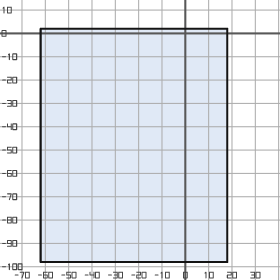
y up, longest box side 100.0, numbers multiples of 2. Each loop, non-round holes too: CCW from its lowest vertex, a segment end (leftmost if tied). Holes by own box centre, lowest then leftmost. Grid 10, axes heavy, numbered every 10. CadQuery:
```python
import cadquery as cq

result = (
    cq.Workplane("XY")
    .moveTo(-62.0, -98.0)
    .lineTo(18.0, -98.0)
    .lineTo(18.0, 2.0)
    .lineTo(-62.0, 2.0)
    .close()
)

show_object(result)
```